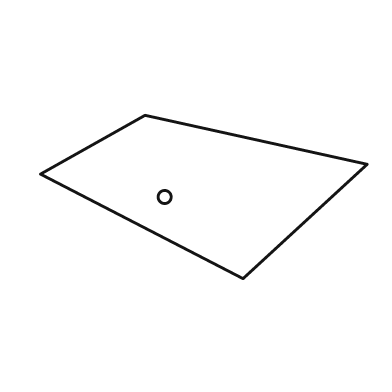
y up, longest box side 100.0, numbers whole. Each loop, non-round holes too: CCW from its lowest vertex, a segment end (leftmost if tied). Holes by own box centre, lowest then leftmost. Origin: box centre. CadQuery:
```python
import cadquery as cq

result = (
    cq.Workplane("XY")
    .moveTo(12.0, -25.0)
    .lineTo(50.0, 10.0)
    .lineTo(-18.0, 25.0)
    .lineTo(-50.0, 7.0)
    .close()
    .moveTo(-12.0, 0.0)
    .circle(2.0)
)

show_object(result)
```